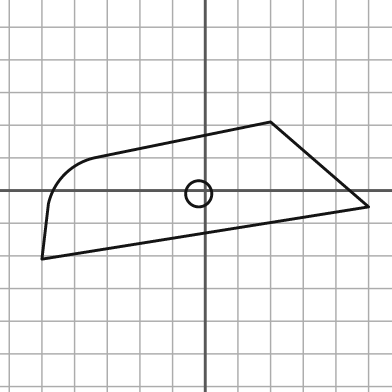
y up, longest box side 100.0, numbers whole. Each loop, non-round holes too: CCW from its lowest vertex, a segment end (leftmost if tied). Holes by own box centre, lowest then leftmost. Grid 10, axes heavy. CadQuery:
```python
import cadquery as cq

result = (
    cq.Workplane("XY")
    .moveTo(-50.0, -21.0)
    .lineTo(50.0, -5.0)
    .lineTo(20.0, 21.0)
    .lineTo(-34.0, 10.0)
    .threePointArc((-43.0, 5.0), (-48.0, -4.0))
    .close()
    .moveTo(-2.0, -1.0)
    .circle(4.0)
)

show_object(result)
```